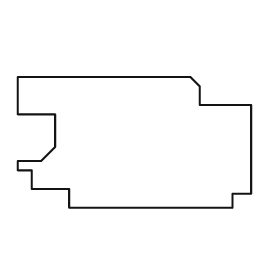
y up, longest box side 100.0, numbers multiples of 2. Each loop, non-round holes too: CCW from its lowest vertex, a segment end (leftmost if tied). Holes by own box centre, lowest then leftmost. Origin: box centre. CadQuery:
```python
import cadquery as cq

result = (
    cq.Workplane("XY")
    .moveTo(-28.0, -28.0)
    .lineTo(42.0, -28.0)
    .lineTo(42.0, -22.0)
    .lineTo(50.0, -22.0)
    .lineTo(50.0, 16.0)
    .lineTo(28.0, 16.0)
    .lineTo(28.0, 24.0)
    .lineTo(24.0, 28.0)
    .lineTo(-50.0, 28.0)
    .lineTo(-50.0, 12.0)
    .lineTo(-34.0, 12.0)
    .lineTo(-34.0, -2.0)
    .lineTo(-40.0, -8.0)
    .lineTo(-50.0, -8.0)
    .lineTo(-50.0, -12.0)
    .lineTo(-44.0, -12.0)
    .lineTo(-44.0, -20.0)
    .lineTo(-28.0, -20.0)
    .close()
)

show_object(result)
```